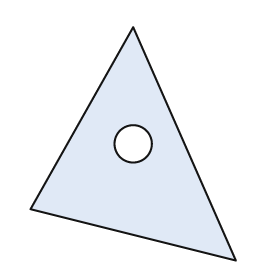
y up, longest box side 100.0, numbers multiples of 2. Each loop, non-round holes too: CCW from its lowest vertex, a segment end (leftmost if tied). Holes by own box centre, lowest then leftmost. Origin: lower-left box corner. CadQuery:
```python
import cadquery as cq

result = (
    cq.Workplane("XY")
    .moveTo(88.0, 0.0)
    .lineTo(44.0, 100.0)
    .lineTo(0.0, 22.0)
    .close()
    .moveTo(44.0, 50.0)
    .circle(8.0)
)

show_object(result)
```